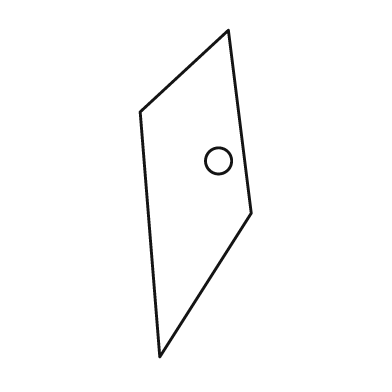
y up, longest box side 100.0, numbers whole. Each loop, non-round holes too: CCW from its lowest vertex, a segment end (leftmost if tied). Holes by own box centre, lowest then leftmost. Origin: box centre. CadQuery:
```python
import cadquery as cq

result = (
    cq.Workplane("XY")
    .moveTo(-11.0, -50.0)
    .lineTo(17.0, -6.0)
    .lineTo(10.0, 50.0)
    .lineTo(-17.0, 25.0)
    .close()
    .moveTo(7.0, 10.0)
    .circle(4.0)
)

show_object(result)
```